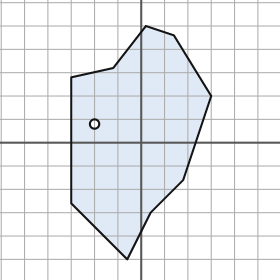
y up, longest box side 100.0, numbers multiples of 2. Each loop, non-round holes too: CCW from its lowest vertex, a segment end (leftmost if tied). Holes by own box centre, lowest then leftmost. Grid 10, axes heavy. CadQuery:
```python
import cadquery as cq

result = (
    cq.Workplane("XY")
    .moveTo(-6.0, -50.0)
    .lineTo(4.0, -30.0)
    .lineTo(18.0, -16.0)
    .lineTo(30.0, 20.0)
    .lineTo(14.0, 46.0)
    .lineTo(2.0, 50.0)
    .lineTo(-12.0, 32.0)
    .lineTo(-30.0, 28.0)
    .lineTo(-30.0, -26.0)
    .close()
    .moveTo(-20.0, 8.0)
    .circle(2.0)
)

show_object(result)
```